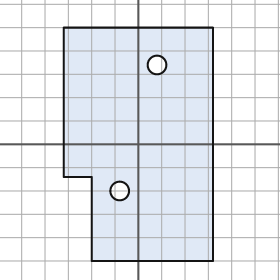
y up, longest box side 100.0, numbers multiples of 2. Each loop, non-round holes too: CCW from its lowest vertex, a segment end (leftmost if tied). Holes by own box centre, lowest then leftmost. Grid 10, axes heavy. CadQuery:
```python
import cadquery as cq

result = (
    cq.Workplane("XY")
    .moveTo(-20.0, -50.0)
    .lineTo(32.0, -50.0)
    .lineTo(32.0, 50.0)
    .lineTo(-32.0, 50.0)
    .lineTo(-32.0, -14.0)
    .lineTo(-20.0, -14.0)
    .close()
    .moveTo(-8.0, -20.0)
    .circle(4.0)
    .moveTo(8.0, 34.0)
    .circle(4.0)
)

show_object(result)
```